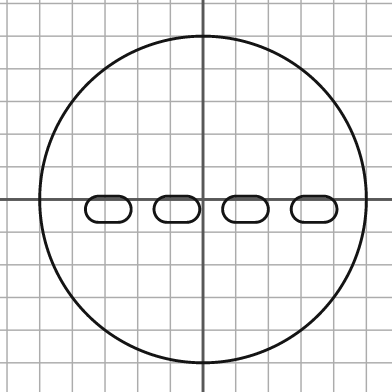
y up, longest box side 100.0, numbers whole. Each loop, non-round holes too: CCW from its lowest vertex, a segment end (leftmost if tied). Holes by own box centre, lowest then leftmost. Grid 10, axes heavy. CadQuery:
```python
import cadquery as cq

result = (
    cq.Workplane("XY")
    .moveTo(0.0, 0.0)
    .circle(50.0)
    .moveTo(-32.0, -7.0)
    .lineTo(-26.0, -7.0)
    .threePointArc((-22.0, -3.0), (-26.0, 1.0))
    .lineTo(-32.0, 1.0)
    .threePointArc((-36.0, -3.0), (-32.0, -7.0))
    .close()
    .moveTo(-11.0, -7.0)
    .lineTo(-5.0, -7.0)
    .threePointArc((-1.0, -3.0), (-5.0, 1.0))
    .lineTo(-11.0, 1.0)
    .threePointArc((-15.0, -3.0), (-11.0, -7.0))
    .close()
    .moveTo(10.0, -7.0)
    .lineTo(16.0, -7.0)
    .threePointArc((20.0, -3.0), (16.0, 1.0))
    .lineTo(10.0, 1.0)
    .threePointArc((6.0, -3.0), (10.0, -7.0))
    .close()
    .moveTo(31.0, -7.0)
    .lineTo(37.0, -7.0)
    .threePointArc((41.0, -3.0), (37.0, 1.0))
    .lineTo(31.0, 1.0)
    .threePointArc((27.0, -3.0), (31.0, -7.0))
    .close()
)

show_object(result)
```